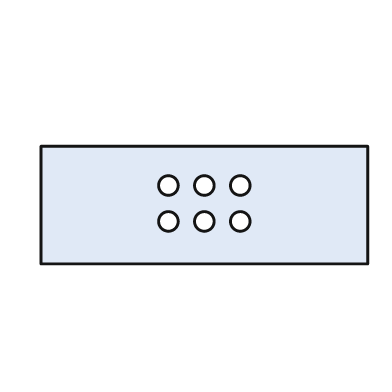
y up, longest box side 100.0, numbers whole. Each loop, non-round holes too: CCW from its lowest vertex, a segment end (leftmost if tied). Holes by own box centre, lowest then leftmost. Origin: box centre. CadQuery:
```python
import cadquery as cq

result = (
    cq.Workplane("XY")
    .moveTo(-50.0, -18.0)
    .lineTo(50.0, -18.0)
    .lineTo(50.0, 18.0)
    .lineTo(-50.0, 18.0)
    .close()
    .moveTo(-11.0, -5.0)
    .circle(3.0)
    .moveTo(0.0, -5.0)
    .circle(3.0)
    .moveTo(11.0, -5.0)
    .circle(3.0)
    .moveTo(-11.0, 6.0)
    .circle(3.0)
    .moveTo(0.0, 6.0)
    .circle(3.0)
    .moveTo(11.0, 6.0)
    .circle(3.0)
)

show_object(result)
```